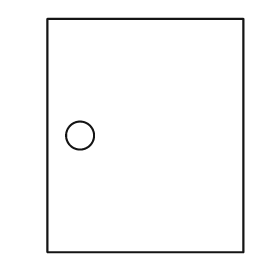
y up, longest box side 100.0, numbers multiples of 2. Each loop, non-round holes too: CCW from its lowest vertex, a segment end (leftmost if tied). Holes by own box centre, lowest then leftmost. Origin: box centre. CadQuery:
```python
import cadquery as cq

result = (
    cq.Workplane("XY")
    .moveTo(-42.0, -50.0)
    .lineTo(42.0, -50.0)
    .lineTo(42.0, 50.0)
    .lineTo(-42.0, 50.0)
    .close()
    .moveTo(-28.0, 0.0)
    .circle(6.0)
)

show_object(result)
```